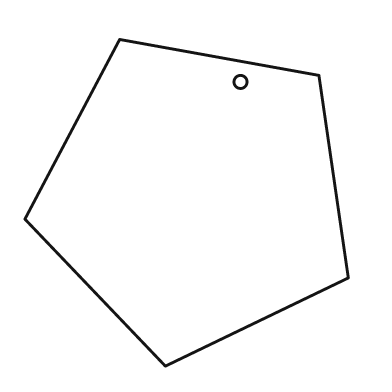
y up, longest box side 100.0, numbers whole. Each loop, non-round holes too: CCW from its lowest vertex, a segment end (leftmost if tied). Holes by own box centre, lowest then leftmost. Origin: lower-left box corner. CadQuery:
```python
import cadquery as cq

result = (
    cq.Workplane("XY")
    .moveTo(43.0, 0.0)
    .lineTo(99.0, 27.0)
    .lineTo(90.0, 89.0)
    .lineTo(29.0, 100.0)
    .lineTo(0.0, 45.0)
    .close()
    .moveTo(66.0, 87.0)
    .circle(2.0)
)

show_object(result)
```